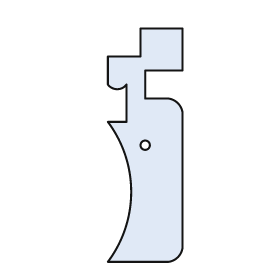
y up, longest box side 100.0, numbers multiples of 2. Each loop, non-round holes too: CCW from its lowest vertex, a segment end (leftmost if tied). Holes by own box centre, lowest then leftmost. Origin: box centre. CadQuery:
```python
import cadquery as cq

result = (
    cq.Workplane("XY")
    .moveTo(-16.0, -50.0)
    .lineTo(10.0, -50.0)
    .threePointArc((14.0, -48.0), (16.0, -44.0))
    .lineTo(16.0, 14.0)
    .threePointArc((14.0, 18.0), (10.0, 20.0))
    .lineTo(0.0, 20.0)
    .lineTo(0.0, 32.0)
    .lineTo(16.0, 32.0)
    .lineTo(16.0, 50.0)
    .lineTo(-2.0, 50.0)
    .lineTo(-2.0, 38.0)
    .lineTo(-16.0, 38.0)
    .lineTo(-16.0, 26.0)
    .threePointArc((-12.0, 24.0), (-8.0, 26.0))
    .lineTo(-8.0, 10.0)
    .lineTo(-16.0, 10.0)
    .threePointArc((-6.0, -20.0), (-16.0, -50.0))
    .close()
    .moveTo(0.0, 0.0)
    .circle(2.0)
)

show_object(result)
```